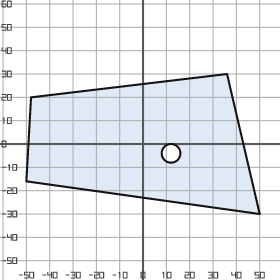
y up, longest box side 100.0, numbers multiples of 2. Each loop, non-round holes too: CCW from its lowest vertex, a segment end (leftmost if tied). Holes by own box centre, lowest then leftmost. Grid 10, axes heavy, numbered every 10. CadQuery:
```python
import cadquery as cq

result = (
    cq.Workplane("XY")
    .moveTo(50.0, -30.0)
    .lineTo(36.0, 30.0)
    .lineTo(-48.0, 20.0)
    .lineTo(-50.0, -16.0)
    .close()
    .moveTo(12.0, -4.0)
    .circle(4.0)
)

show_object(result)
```